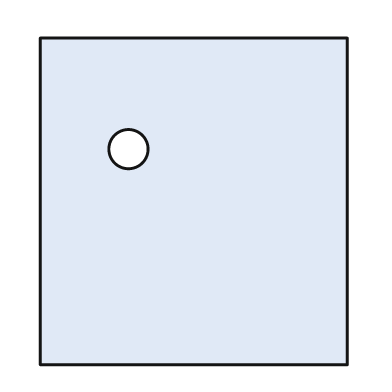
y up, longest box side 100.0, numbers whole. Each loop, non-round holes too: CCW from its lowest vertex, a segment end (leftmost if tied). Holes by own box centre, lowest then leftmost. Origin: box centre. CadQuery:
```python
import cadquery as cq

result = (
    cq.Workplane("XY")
    .moveTo(-47.0, -50.0)
    .lineTo(47.0, -50.0)
    .lineTo(47.0, 50.0)
    .lineTo(-47.0, 50.0)
    .close()
    .moveTo(-20.0, 16.0)
    .circle(6.0)
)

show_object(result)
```